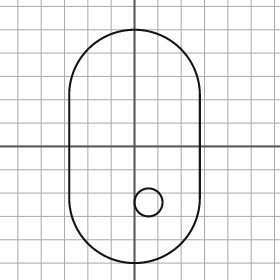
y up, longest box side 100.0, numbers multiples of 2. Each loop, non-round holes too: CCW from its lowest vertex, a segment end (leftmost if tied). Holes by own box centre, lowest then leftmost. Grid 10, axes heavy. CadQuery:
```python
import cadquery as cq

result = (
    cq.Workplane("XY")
    .moveTo(-28.0, -22.0)
    .threePointArc((0.0, -50.0), (28.0, -22.0))
    .lineTo(28.0, 22.0)
    .threePointArc((0.0, 50.0), (-28.0, 22.0))
    .close()
    .moveTo(6.0, -24.0)
    .circle(6.0)
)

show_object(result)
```